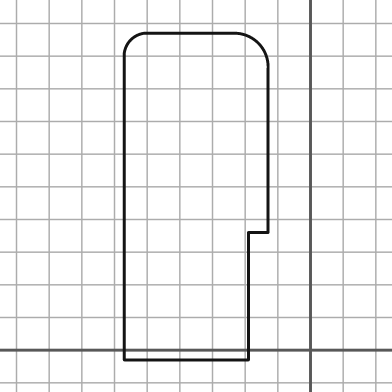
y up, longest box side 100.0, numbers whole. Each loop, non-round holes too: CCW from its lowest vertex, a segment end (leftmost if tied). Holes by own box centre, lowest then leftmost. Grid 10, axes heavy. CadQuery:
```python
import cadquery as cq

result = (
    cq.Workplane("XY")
    .moveTo(-57.0, -3.0)
    .lineTo(-19.0, -3.0)
    .lineTo(-19.0, 36.0)
    .lineTo(-13.0, 36.0)
    .lineTo(-13.0, 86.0)
    .threePointArc((-16.0, 94.0), (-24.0, 97.0))
    .lineTo(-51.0, 97.0)
    .threePointArc((-55.0, 95.0), (-57.0, 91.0))
    .close()
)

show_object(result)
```